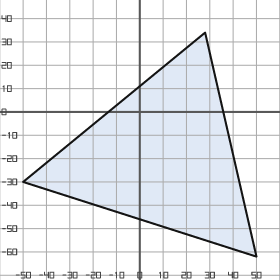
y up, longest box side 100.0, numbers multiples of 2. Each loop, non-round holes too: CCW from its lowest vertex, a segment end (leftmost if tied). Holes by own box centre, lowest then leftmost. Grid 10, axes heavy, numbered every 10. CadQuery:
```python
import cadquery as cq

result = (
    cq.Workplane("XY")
    .moveTo(50.0, -62.0)
    .lineTo(28.0, 34.0)
    .lineTo(-50.0, -30.0)
    .close()
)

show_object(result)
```